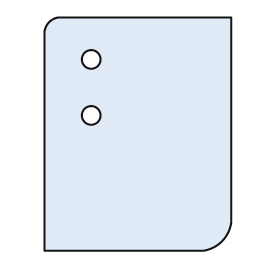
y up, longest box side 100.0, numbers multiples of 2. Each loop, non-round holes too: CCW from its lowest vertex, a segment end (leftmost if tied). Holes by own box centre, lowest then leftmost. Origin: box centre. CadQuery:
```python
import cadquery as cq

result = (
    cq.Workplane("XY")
    .moveTo(-40.0, -50.0)
    .lineTo(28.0, -50.0)
    .threePointArc((36.0, -46.0), (40.0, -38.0))
    .lineTo(40.0, 50.0)
    .lineTo(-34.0, 50.0)
    .threePointArc((-38.0, 48.0), (-40.0, 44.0))
    .close()
    .moveTo(-20.0, 8.0)
    .circle(4.0)
    .moveTo(-20.0, 32.0)
    .circle(4.0)
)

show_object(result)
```